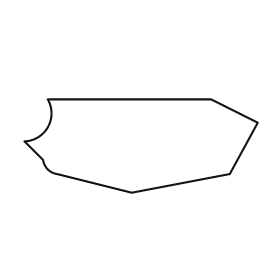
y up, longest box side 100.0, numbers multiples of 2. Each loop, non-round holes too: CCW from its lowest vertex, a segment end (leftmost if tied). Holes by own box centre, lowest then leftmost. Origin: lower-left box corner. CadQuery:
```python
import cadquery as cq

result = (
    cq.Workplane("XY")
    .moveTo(46.0, 0.0)
    .lineTo(88.0, 8.0)
    .lineTo(100.0, 30.0)
    .lineTo(80.0, 40.0)
    .lineTo(10.0, 40.0)
    .threePointArc((10.0, 28.0), (0.0, 22.0))
    .lineTo(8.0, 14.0)
    .threePointArc((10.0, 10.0), (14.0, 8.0))
    .close()
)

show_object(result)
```